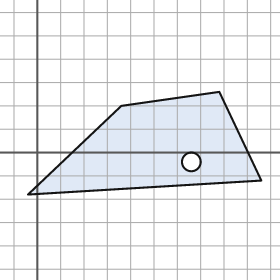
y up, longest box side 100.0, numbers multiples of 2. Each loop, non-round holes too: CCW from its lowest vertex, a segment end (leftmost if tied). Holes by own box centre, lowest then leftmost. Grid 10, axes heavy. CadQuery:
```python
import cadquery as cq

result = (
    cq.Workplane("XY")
    .moveTo(-4.0, -18.0)
    .lineTo(96.0, -12.0)
    .lineTo(78.0, 26.0)
    .lineTo(36.0, 20.0)
    .close()
    .moveTo(66.0, -4.0)
    .circle(4.0)
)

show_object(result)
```